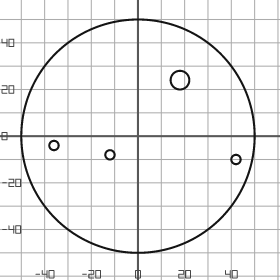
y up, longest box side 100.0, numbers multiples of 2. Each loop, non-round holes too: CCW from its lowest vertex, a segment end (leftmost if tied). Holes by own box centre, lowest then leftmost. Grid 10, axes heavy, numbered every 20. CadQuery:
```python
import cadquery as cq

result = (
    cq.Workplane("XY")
    .moveTo(0.0, 0.0)
    .circle(50.0)
    .moveTo(42.0, -10.0)
    .circle(2.0)
    .moveTo(-12.0, -8.0)
    .circle(2.0)
    .moveTo(-36.0, -4.0)
    .circle(2.0)
    .moveTo(18.0, 24.0)
    .circle(4.0)
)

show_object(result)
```